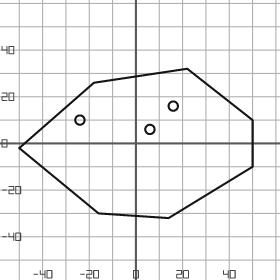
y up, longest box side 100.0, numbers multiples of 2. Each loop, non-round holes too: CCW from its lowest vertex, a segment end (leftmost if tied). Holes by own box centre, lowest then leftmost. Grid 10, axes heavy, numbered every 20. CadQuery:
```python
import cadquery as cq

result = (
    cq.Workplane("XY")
    .moveTo(14.0, -32.0)
    .lineTo(50.0, -10.0)
    .lineTo(50.0, 10.0)
    .lineTo(22.0, 32.0)
    .lineTo(-18.0, 26.0)
    .lineTo(-50.0, -2.0)
    .lineTo(-16.0, -30.0)
    .close()
    .moveTo(6.0, 6.0)
    .circle(2.0)
    .moveTo(-24.0, 10.0)
    .circle(2.0)
    .moveTo(16.0, 16.0)
    .circle(2.0)
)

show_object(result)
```